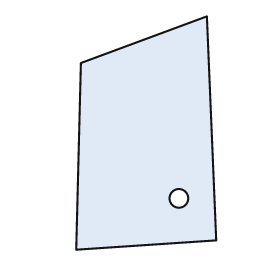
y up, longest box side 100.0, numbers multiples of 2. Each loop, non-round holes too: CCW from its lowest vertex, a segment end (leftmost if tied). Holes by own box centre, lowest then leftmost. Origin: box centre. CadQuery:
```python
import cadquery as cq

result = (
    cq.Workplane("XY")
    .moveTo(-30.0, -50.0)
    .lineTo(30.0, -46.0)
    .lineTo(26.0, 50.0)
    .lineTo(-28.0, 30.0)
    .close()
    .moveTo(14.0, -28.0)
    .circle(4.0)
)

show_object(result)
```